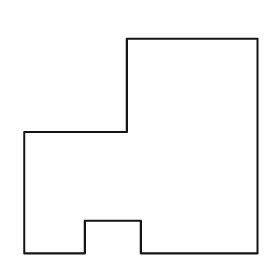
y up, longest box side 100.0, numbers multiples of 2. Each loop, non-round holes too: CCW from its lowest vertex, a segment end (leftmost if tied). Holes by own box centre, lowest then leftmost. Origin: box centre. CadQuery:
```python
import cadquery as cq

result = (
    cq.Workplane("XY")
    .moveTo(-50.0, -46.0)
    .lineTo(-24.0, -46.0)
    .lineTo(-24.0, -32.0)
    .lineTo(0.0, -32.0)
    .lineTo(0.0, -46.0)
    .lineTo(50.0, -46.0)
    .lineTo(50.0, 46.0)
    .lineTo(-6.0, 46.0)
    .lineTo(-6.0, 6.0)
    .lineTo(-50.0, 6.0)
    .close()
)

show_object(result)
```